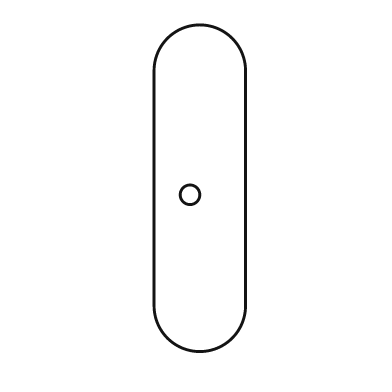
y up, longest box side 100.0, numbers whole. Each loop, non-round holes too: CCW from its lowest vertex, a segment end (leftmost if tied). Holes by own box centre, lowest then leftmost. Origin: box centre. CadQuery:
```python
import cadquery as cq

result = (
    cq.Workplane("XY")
    .moveTo(-14.0, -36.0)
    .threePointArc((0.0, -50.0), (14.0, -36.0))
    .lineTo(14.0, 36.0)
    .threePointArc((0.0, 50.0), (-14.0, 36.0))
    .close()
    .moveTo(-3.0, -2.0)
    .circle(3.0)
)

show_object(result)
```